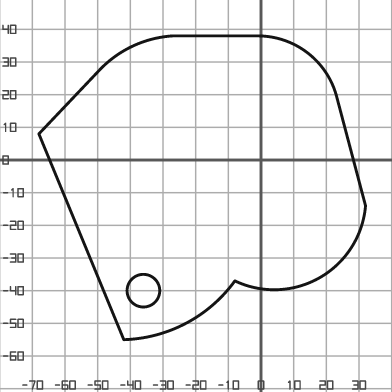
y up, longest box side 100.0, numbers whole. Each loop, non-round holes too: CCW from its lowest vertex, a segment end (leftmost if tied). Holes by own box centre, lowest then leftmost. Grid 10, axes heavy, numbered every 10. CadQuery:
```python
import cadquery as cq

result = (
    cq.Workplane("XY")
    .moveTo(-42.0, -55.0)
    .threePointArc((-23.0, -50.0), (-8.0, -37.0))
    .threePointArc((18.0, -36.0), (32.0, -14.0))
    .lineTo(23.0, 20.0)
    .threePointArc((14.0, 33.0), (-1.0, 38.0))
    .lineTo(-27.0, 38.0)
    .threePointArc((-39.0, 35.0), (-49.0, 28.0))
    .lineTo(-68.0, 8.0)
    .close()
    .moveTo(-36.0, -40.0)
    .circle(5.0)
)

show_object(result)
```